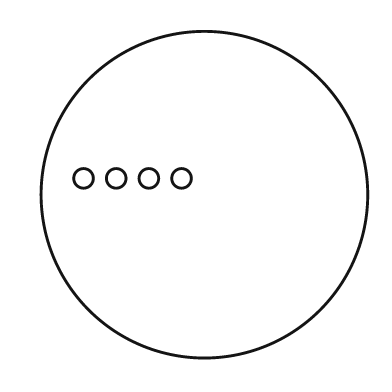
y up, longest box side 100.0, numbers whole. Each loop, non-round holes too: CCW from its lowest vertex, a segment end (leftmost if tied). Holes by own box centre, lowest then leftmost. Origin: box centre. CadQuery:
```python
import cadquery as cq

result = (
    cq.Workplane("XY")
    .moveTo(0.0, 0.0)
    .circle(50.0)
    .moveTo(-37.0, 5.0)
    .circle(3.0)
    .moveTo(-27.0, 5.0)
    .circle(3.0)
    .moveTo(-17.0, 5.0)
    .circle(3.0)
    .moveTo(-7.0, 5.0)
    .circle(3.0)
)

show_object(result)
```